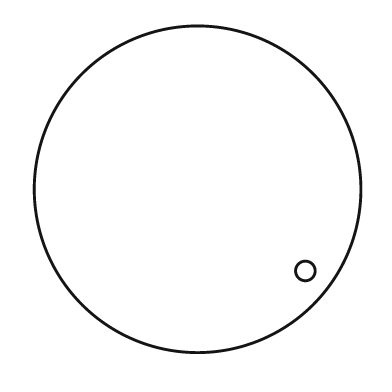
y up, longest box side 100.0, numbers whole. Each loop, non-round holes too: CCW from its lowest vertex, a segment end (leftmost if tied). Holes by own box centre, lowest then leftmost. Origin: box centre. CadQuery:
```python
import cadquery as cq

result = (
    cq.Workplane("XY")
    .moveTo(0.0, 0.0)
    .circle(50.0)
    .moveTo(33.0, -25.0)
    .circle(3.0)
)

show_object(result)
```